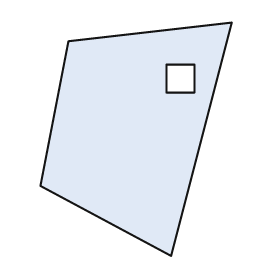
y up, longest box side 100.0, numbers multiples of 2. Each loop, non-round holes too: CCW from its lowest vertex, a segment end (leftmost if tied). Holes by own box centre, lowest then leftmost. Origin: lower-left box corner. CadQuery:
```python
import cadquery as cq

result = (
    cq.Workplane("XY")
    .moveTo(56.0, 0.0)
    .lineTo(82.0, 100.0)
    .lineTo(12.0, 92.0)
    .lineTo(0.0, 30.0)
    .close()
    .moveTo(54.0, 70.0)
    .lineTo(66.0, 70.0)
    .lineTo(66.0, 82.0)
    .lineTo(54.0, 82.0)
    .close()
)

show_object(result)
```